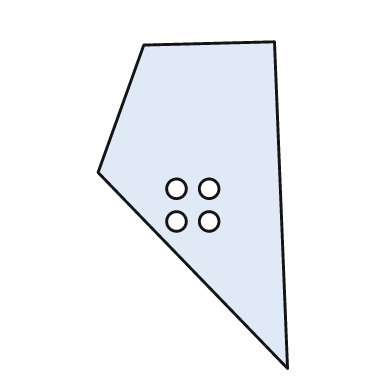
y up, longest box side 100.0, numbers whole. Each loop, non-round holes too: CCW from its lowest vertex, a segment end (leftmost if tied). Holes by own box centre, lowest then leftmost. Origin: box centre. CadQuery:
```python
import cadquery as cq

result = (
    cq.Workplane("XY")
    .moveTo(29.0, -50.0)
    .lineTo(25.0, 50.0)
    .lineTo(-15.0, 49.0)
    .lineTo(-29.0, 10.0)
    .close()
    .moveTo(-5.0, -5.0)
    .circle(3.0)
    .moveTo(5.0, -5.0)
    .circle(3.0)
    .moveTo(-5.0, 5.0)
    .circle(3.0)
    .moveTo(5.0, 5.0)
    .circle(3.0)
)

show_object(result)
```